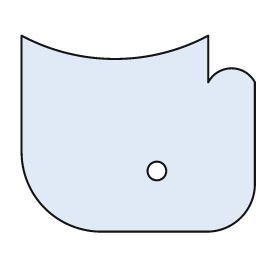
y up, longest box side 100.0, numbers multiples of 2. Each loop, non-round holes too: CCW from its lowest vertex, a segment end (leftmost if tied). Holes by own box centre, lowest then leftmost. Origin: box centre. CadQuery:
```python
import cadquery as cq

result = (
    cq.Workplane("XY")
    .moveTo(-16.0, -42.0)
    .lineTo(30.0, -42.0)
    .threePointArc((44.0, -36.0), (50.0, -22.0))
    .lineTo(50.0, 22.0)
    .threePointArc((40.0, 28.0), (30.0, 22.0))
    .lineTo(30.0, 42.0)
    .threePointArc((-10.0, 32.0), (-50.0, 42.0))
    .lineTo(-50.0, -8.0)
    .threePointArc((-40.0, -32.0), (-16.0, -42.0))
    .close()
    .moveTo(8.0, -16.0)
    .circle(4.0)
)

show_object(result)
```